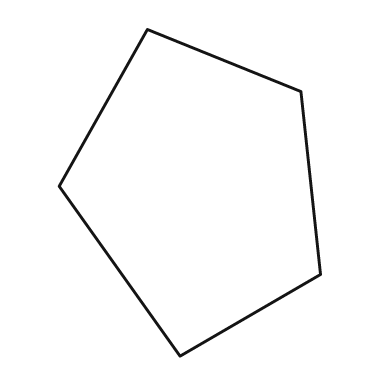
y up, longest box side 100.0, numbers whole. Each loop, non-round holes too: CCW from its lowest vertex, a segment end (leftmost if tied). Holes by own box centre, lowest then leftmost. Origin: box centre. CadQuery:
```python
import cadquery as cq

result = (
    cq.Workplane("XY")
    .moveTo(-3.0, -50.0)
    .lineTo(40.0, -25.0)
    .lineTo(34.0, 31.0)
    .lineTo(-13.0, 50.0)
    .lineTo(-40.0, 2.0)
    .close()
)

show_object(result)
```